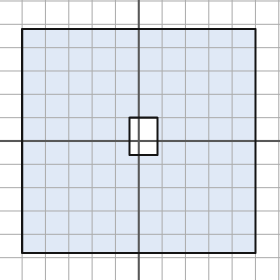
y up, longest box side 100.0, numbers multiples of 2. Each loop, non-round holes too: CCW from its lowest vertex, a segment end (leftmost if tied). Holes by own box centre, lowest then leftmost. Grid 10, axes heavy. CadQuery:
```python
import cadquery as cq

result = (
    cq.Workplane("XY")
    .moveTo(-50.0, -48.0)
    .lineTo(50.0, -48.0)
    .lineTo(50.0, 48.0)
    .lineTo(-50.0, 48.0)
    .close()
    .moveTo(-4.0, -6.0)
    .lineTo(8.0, -6.0)
    .lineTo(8.0, 10.0)
    .lineTo(-4.0, 10.0)
    .close()
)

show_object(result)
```